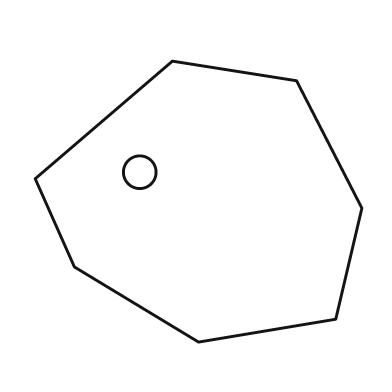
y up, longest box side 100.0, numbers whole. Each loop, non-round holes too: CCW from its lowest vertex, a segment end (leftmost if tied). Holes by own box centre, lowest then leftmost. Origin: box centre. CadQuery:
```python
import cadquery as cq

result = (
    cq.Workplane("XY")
    .moveTo(0.0, -43.0)
    .lineTo(42.0, -36.0)
    .lineTo(50.0, -2.0)
    .lineTo(30.0, 37.0)
    .lineTo(-8.0, 43.0)
    .lineTo(-50.0, 7.0)
    .lineTo(-38.0, -20.0)
    .close()
    .moveTo(-18.0, 9.0)
    .circle(5.0)
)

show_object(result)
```